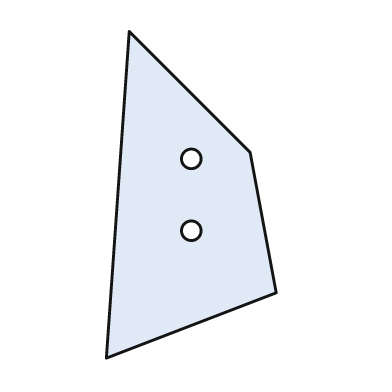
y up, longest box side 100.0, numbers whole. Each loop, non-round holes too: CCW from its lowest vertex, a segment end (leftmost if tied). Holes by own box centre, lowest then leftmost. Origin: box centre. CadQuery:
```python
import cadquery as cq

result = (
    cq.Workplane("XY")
    .moveTo(-26.0, -50.0)
    .lineTo(26.0, -30.0)
    .lineTo(18.0, 13.0)
    .lineTo(-19.0, 50.0)
    .close()
    .moveTo(0.0, -11.0)
    .circle(3.0)
    .moveTo(0.0, 11.0)
    .circle(3.0)
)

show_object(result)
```